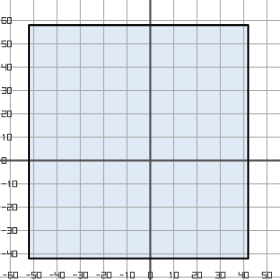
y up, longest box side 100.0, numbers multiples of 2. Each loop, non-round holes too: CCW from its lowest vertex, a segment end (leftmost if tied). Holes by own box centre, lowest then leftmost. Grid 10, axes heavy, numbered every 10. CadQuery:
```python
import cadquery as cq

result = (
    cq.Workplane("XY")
    .moveTo(-52.0, -42.0)
    .lineTo(42.0, -42.0)
    .lineTo(42.0, 58.0)
    .lineTo(-52.0, 58.0)
    .close()
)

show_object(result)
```